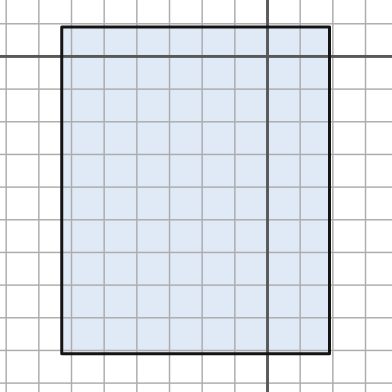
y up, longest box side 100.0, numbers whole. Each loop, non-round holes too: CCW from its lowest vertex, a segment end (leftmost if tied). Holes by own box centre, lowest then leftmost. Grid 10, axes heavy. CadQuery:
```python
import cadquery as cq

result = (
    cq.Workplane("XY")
    .moveTo(-63.0, -91.0)
    .lineTo(19.0, -91.0)
    .lineTo(19.0, 9.0)
    .lineTo(-63.0, 9.0)
    .close()
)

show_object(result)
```